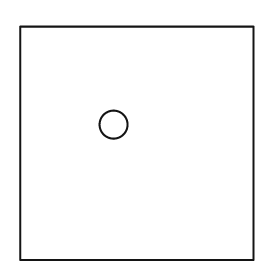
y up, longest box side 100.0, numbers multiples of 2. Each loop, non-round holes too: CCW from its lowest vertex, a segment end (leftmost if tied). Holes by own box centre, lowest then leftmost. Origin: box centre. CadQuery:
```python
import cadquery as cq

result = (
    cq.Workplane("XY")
    .moveTo(-50.0, -50.0)
    .lineTo(50.0, -50.0)
    .lineTo(50.0, 50.0)
    .lineTo(-50.0, 50.0)
    .close()
    .moveTo(-10.0, 8.0)
    .circle(6.0)
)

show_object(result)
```